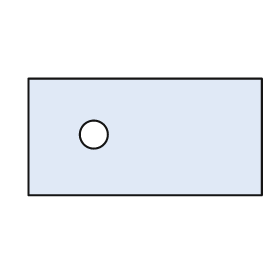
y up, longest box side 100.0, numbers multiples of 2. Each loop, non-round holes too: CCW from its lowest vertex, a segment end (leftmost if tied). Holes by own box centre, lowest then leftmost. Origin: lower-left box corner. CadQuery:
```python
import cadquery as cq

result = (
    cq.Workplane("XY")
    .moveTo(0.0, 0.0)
    .lineTo(100.0, 0.0)
    .lineTo(100.0, 50.0)
    .lineTo(0.0, 50.0)
    .close()
    .moveTo(28.0, 26.0)
    .circle(6.0)
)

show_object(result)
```